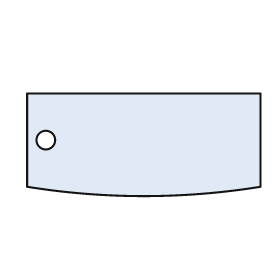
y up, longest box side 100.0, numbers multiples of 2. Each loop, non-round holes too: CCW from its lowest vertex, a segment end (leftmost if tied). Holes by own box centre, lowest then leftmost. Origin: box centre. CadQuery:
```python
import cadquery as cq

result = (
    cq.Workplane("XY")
    .moveTo(-50.0, -18.0)
    .threePointArc((0.0, -22.0), (50.0, -18.0))
    .lineTo(50.0, 22.0)
    .lineTo(-50.0, 22.0)
    .close()
    .moveTo(-42.0, 2.0)
    .circle(4.0)
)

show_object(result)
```